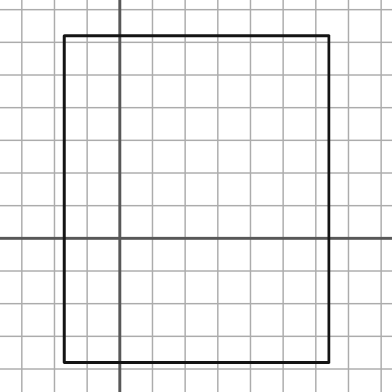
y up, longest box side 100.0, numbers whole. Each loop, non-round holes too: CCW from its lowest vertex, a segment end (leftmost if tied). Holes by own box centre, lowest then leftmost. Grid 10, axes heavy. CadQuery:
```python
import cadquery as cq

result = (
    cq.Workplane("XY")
    .moveTo(-17.0, -38.0)
    .lineTo(64.0, -38.0)
    .lineTo(64.0, 62.0)
    .lineTo(-17.0, 62.0)
    .close()
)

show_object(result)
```